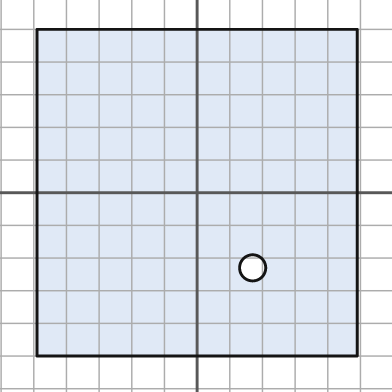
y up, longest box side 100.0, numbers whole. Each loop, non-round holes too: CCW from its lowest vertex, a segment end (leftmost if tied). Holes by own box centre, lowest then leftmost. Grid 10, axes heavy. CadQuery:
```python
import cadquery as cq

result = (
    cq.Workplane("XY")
    .moveTo(-49.0, -50.0)
    .lineTo(49.0, -50.0)
    .lineTo(49.0, 50.0)
    .lineTo(-49.0, 50.0)
    .close()
    .moveTo(17.0, -23.0)
    .circle(4.0)
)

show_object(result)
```